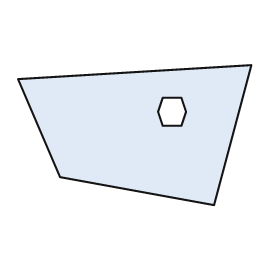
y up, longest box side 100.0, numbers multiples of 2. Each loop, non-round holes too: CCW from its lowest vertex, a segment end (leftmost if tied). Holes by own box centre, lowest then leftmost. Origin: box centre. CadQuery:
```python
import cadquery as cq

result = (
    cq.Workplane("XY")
    .moveTo(34.0, -30.0)
    .lineTo(50.0, 30.0)
    .lineTo(-50.0, 24.0)
    .lineTo(-32.0, -18.0)
    .close()
    .moveTo(12.0, 4.0)
    .lineTo(20.0, 4.0)
    .lineTo(22.0, 10.0)
    .lineTo(20.0, 16.0)
    .lineTo(12.0, 16.0)
    .lineTo(10.0, 10.0)
    .close()
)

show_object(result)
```